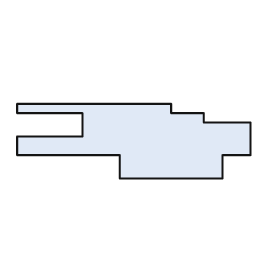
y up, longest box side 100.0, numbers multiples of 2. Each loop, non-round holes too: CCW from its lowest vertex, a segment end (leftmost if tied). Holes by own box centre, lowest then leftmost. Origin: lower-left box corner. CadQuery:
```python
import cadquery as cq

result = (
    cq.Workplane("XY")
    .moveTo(44.0, 0.0)
    .lineTo(88.0, 0.0)
    .lineTo(88.0, 10.0)
    .lineTo(100.0, 10.0)
    .lineTo(100.0, 24.0)
    .lineTo(80.0, 24.0)
    .lineTo(80.0, 28.0)
    .lineTo(66.0, 28.0)
    .lineTo(66.0, 32.0)
    .lineTo(0.0, 32.0)
    .lineTo(0.0, 28.0)
    .lineTo(28.0, 28.0)
    .lineTo(28.0, 18.0)
    .lineTo(0.0, 18.0)
    .lineTo(0.0, 10.0)
    .lineTo(44.0, 10.0)
    .close()
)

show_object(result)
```